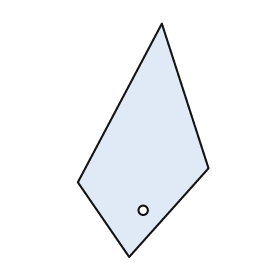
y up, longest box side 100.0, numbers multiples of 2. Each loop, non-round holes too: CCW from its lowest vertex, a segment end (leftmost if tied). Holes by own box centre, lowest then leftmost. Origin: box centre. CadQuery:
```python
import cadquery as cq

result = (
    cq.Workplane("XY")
    .moveTo(-6.0, -50.0)
    .lineTo(28.0, -12.0)
    .lineTo(8.0, 50.0)
    .lineTo(-28.0, -18.0)
    .close()
    .moveTo(0.0, -30.0)
    .circle(2.0)
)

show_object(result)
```